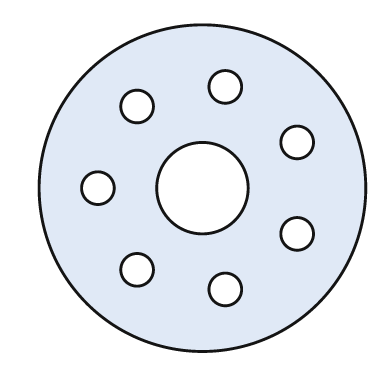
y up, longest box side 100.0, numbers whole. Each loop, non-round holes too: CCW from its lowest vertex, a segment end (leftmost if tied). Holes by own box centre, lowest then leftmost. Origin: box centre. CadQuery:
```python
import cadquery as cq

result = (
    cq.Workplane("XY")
    .moveTo(0.0, 0.0)
    .circle(50.0)
    .moveTo(7.0, -31.0)
    .circle(5.0)
    .moveTo(-20.0, -25.0)
    .circle(5.0)
    .moveTo(29.0, -14.0)
    .circle(5.0)
    .moveTo(-32.0, 0.0)
    .circle(5.0)
    .moveTo(0.0, 0.0)
    .circle(14.0)
    .moveTo(29.0, 14.0)
    .circle(5.0)
    .moveTo(-20.0, 25.0)
    .circle(5.0)
    .moveTo(7.0, 31.0)
    .circle(5.0)
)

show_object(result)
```